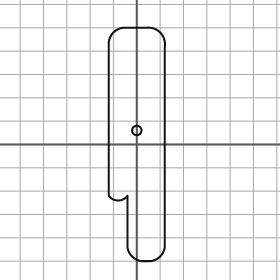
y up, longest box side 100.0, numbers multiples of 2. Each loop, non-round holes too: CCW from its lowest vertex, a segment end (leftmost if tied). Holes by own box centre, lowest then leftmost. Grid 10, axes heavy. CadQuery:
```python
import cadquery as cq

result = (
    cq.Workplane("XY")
    .moveTo(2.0, -50.0)
    .lineTo(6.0, -50.0)
    .threePointArc((10.0, -48.0), (12.0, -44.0))
    .lineTo(12.0, 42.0)
    .threePointArc((10.0, 48.0), (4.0, 50.0))
    .lineTo(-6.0, 50.0)
    .threePointArc((-10.0, 48.0), (-12.0, 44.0))
    .lineTo(-12.0, -22.0)
    .threePointArc((-8.0, -24.0), (-4.0, -22.0))
    .lineTo(-4.0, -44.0)
    .threePointArc((-2.0, -48.0), (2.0, -50.0))
    .close()
    .moveTo(0.0, 6.0)
    .circle(2.0)
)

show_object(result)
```